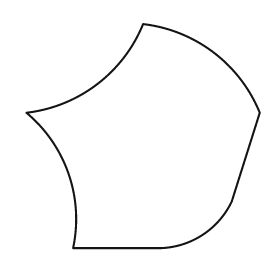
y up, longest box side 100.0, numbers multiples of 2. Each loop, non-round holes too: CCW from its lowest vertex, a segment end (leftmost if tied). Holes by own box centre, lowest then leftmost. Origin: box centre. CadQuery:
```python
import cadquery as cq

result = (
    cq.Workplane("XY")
    .moveTo(-30.0, -48.0)
    .lineTo(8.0, -48.0)
    .threePointArc((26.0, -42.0), (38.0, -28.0))
    .lineTo(50.0, 10.0)
    .threePointArc((30.0, 36.0), (0.0, 48.0))
    .threePointArc((-20.0, 22.0), (-50.0, 10.0))
    .threePointArc((-32.0, -16.0), (-30.0, -48.0))
    .close()
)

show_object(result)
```